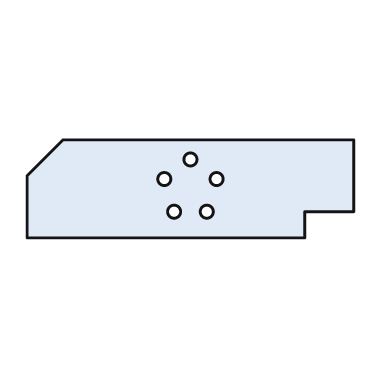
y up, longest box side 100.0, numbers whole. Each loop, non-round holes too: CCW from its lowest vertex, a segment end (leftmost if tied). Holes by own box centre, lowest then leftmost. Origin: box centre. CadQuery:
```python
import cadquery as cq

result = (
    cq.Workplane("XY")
    .moveTo(-50.0, -15.0)
    .lineTo(35.0, -15.0)
    .lineTo(35.0, -7.0)
    .lineTo(50.0, -7.0)
    .lineTo(50.0, 15.0)
    .lineTo(-39.0, 15.0)
    .lineTo(-50.0, 4.0)
    .close()
    .moveTo(-5.0, -7.0)
    .circle(2.0)
    .moveTo(5.0, -7.0)
    .circle(2.0)
    .moveTo(-8.0, 3.0)
    .circle(2.0)
    .moveTo(8.0, 3.0)
    .circle(2.0)
    .moveTo(0.0, 9.0)
    .circle(2.0)
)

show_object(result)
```